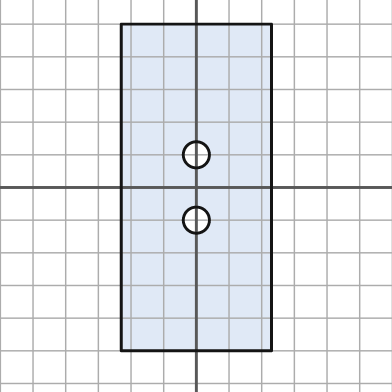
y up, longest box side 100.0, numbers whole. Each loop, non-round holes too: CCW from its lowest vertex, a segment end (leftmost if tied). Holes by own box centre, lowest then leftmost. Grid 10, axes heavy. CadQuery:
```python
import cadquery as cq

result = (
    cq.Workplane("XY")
    .moveTo(-23.0, -50.0)
    .lineTo(23.0, -50.0)
    .lineTo(23.0, 50.0)
    .lineTo(-23.0, 50.0)
    .close()
    .moveTo(0.0, -10.0)
    .circle(4.0)
    .moveTo(0.0, 10.0)
    .circle(4.0)
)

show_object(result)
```